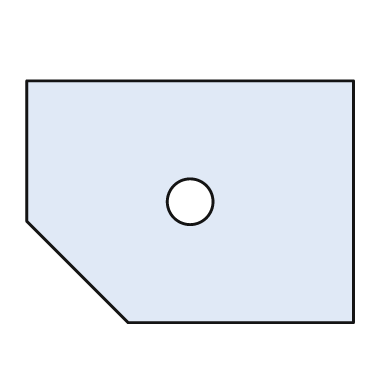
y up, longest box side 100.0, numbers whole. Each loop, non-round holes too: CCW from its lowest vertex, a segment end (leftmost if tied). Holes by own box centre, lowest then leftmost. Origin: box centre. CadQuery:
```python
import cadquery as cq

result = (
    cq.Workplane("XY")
    .moveTo(-19.0, -37.0)
    .lineTo(50.0, -37.0)
    .lineTo(50.0, 37.0)
    .lineTo(-50.0, 37.0)
    .lineTo(-50.0, -6.0)
    .close()
    .moveTo(0.0, 0.0)
    .circle(7.0)
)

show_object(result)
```